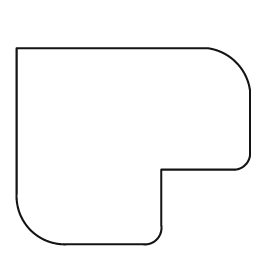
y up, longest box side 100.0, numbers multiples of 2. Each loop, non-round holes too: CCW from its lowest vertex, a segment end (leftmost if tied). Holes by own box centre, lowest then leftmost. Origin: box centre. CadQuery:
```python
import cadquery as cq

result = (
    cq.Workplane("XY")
    .moveTo(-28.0, -42.0)
    .lineTo(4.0, -42.0)
    .threePointArc((10.0, -40.0), (12.0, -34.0))
    .lineTo(12.0, -10.0)
    .lineTo(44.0, -10.0)
    .threePointArc((48.0, -8.0), (50.0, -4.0))
    .lineTo(50.0, 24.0)
    .threePointArc((44.0, 36.0), (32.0, 42.0))
    .lineTo(-50.0, 42.0)
    .lineTo(-50.0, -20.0)
    .threePointArc((-44.0, -36.0), (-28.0, -42.0))
    .close()
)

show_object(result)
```